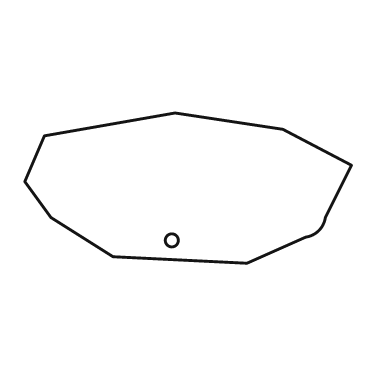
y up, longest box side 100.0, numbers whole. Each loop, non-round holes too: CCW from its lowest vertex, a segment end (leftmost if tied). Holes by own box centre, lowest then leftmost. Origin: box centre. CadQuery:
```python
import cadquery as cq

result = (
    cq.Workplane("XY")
    .moveTo(18.0, -23.0)
    .lineTo(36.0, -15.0)
    .threePointArc((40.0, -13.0), (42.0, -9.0))
    .lineTo(50.0, 7.0)
    .lineTo(29.0, 18.0)
    .lineTo(-4.0, 23.0)
    .lineTo(-44.0, 16.0)
    .lineTo(-50.0, 2.0)
    .lineTo(-42.0, -9.0)
    .lineTo(-23.0, -21.0)
    .close()
    .moveTo(-5.0, -16.0)
    .circle(2.0)
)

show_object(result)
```